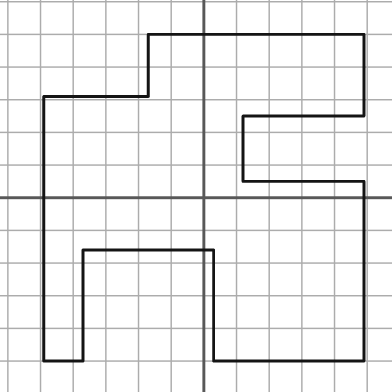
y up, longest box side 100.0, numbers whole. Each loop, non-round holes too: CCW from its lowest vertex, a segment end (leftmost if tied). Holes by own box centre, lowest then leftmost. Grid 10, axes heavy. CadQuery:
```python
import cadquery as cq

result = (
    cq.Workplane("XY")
    .moveTo(-49.0, -50.0)
    .lineTo(-37.0, -50.0)
    .lineTo(-37.0, -16.0)
    .lineTo(3.0, -16.0)
    .lineTo(3.0, -50.0)
    .lineTo(49.0, -50.0)
    .lineTo(49.0, 5.0)
    .lineTo(12.0, 5.0)
    .lineTo(12.0, 25.0)
    .lineTo(49.0, 25.0)
    .lineTo(49.0, 50.0)
    .lineTo(-17.0, 50.0)
    .lineTo(-17.0, 31.0)
    .lineTo(-49.0, 31.0)
    .close()
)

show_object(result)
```